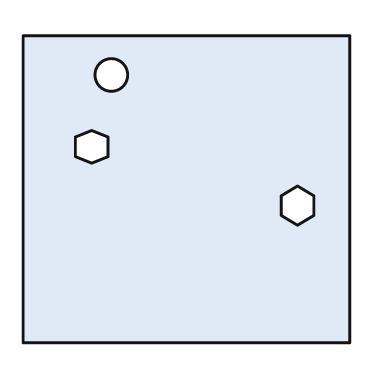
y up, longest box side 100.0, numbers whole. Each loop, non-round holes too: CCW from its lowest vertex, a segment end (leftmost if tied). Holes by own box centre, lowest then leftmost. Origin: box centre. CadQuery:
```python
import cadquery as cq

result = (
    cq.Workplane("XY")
    .moveTo(-50.0, -47.0)
    .lineTo(50.0, -47.0)
    .lineTo(50.0, 47.0)
    .lineTo(-50.0, 47.0)
    .close()
    .moveTo(34.0, -11.0)
    .lineTo(39.0, -8.0)
    .lineTo(39.0, -2.0)
    .lineTo(34.0, 1.0)
    .lineTo(29.0, -2.0)
    .lineTo(29.0, -8.0)
    .close()
    .moveTo(-29.0, 8.0)
    .lineTo(-24.0, 10.0)
    .lineTo(-24.0, 16.0)
    .lineTo(-29.0, 18.0)
    .lineTo(-34.0, 16.0)
    .lineTo(-34.0, 10.0)
    .close()
    .moveTo(-23.0, 35.0)
    .circle(5.0)
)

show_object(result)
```